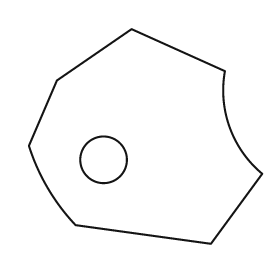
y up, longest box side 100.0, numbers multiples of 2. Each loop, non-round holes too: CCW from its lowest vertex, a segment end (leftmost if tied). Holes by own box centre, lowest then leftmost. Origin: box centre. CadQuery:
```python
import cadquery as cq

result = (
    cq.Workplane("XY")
    .moveTo(28.0, -46.0)
    .lineTo(50.0, -16.0)
    .threePointArc((36.0, 4.0), (34.0, 28.0))
    .lineTo(-6.0, 46.0)
    .lineTo(-38.0, 24.0)
    .lineTo(-50.0, -4.0)
    .threePointArc((-42.0, -22.0), (-30.0, -38.0))
    .close()
    .moveTo(-18.0, -10.0)
    .circle(10.0)
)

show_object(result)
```